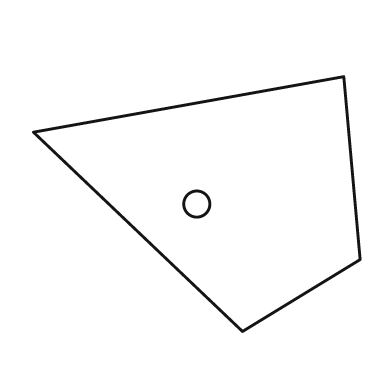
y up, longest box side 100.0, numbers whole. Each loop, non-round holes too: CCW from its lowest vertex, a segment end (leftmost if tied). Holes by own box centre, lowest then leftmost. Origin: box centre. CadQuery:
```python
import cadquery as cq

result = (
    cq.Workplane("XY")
    .moveTo(14.0, -39.0)
    .lineTo(50.0, -17.0)
    .lineTo(45.0, 39.0)
    .lineTo(-50.0, 22.0)
    .close()
    .moveTo(0.0, 0.0)
    .circle(4.0)
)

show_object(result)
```